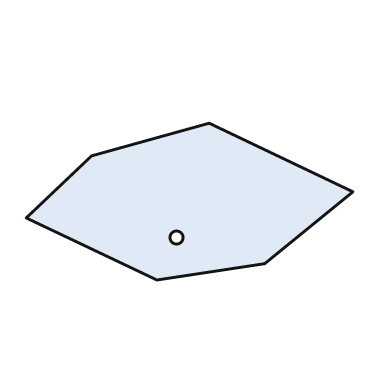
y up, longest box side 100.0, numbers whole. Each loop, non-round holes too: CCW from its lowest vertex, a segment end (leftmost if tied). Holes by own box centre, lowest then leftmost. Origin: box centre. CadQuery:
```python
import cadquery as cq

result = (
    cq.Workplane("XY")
    .moveTo(-10.0, -24.0)
    .lineTo(23.0, -19.0)
    .lineTo(50.0, 3.0)
    .lineTo(6.0, 24.0)
    .lineTo(-30.0, 14.0)
    .lineTo(-50.0, -5.0)
    .close()
    .moveTo(-4.0, -11.0)
    .circle(2.0)
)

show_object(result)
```